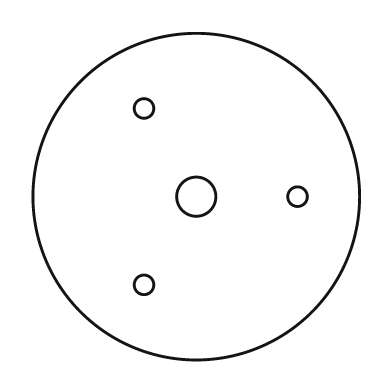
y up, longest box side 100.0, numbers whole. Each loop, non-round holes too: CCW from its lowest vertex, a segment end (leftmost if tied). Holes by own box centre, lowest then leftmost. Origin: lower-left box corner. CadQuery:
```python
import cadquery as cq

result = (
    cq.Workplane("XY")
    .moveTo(50.0, 50.0)
    .circle(50.0)
    .moveTo(34.0, 23.0)
    .circle(3.0)
    .moveTo(50.0, 50.0)
    .circle(6.0)
    .moveTo(81.0, 50.0)
    .circle(3.0)
    .moveTo(34.0, 77.0)
    .circle(3.0)
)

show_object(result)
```